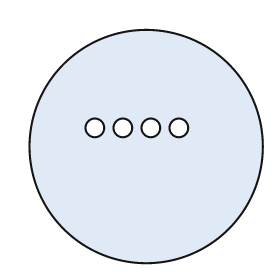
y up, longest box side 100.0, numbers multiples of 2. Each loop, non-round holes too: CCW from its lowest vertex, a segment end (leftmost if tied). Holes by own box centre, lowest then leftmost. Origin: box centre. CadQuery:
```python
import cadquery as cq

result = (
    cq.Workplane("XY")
    .moveTo(0.0, 0.0)
    .circle(50.0)
    .moveTo(-22.0, 8.0)
    .circle(4.0)
    .moveTo(-10.0, 8.0)
    .circle(4.0)
    .moveTo(2.0, 8.0)
    .circle(4.0)
    .moveTo(14.0, 8.0)
    .circle(4.0)
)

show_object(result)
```